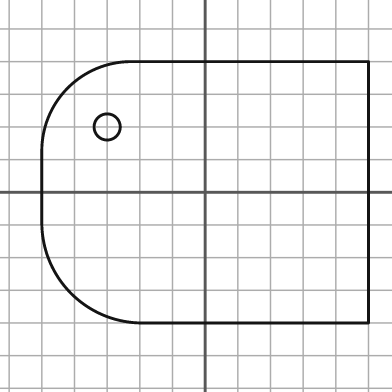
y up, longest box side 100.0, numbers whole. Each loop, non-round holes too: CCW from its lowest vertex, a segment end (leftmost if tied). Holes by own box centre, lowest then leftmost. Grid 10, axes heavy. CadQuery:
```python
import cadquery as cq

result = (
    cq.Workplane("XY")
    .moveTo(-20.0, -40.0)
    .lineTo(50.0, -40.0)
    .lineTo(50.0, 40.0)
    .lineTo(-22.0, 40.0)
    .threePointArc((-42.0, 32.0), (-50.0, 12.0))
    .lineTo(-50.0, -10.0)
    .threePointArc((-41.0, -31.0), (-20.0, -40.0))
    .close()
    .moveTo(-30.0, 20.0)
    .circle(4.0)
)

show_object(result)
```